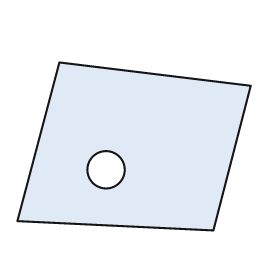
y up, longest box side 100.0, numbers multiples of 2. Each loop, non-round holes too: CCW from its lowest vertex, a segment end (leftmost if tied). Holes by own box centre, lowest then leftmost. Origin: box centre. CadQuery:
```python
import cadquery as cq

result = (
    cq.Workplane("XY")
    .moveTo(34.0, -36.0)
    .lineTo(50.0, 26.0)
    .lineTo(-32.0, 36.0)
    .lineTo(-50.0, -32.0)
    .close()
    .moveTo(-12.0, -10.0)
    .circle(8.0)
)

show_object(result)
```